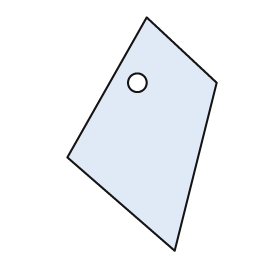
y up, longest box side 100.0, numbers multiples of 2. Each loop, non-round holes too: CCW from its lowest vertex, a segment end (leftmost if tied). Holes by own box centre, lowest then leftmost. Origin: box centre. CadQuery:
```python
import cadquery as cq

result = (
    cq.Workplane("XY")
    .moveTo(14.0, -50.0)
    .lineTo(32.0, 22.0)
    .lineTo(2.0, 50.0)
    .lineTo(-32.0, -10.0)
    .close()
    .moveTo(-2.0, 22.0)
    .circle(4.0)
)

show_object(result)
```